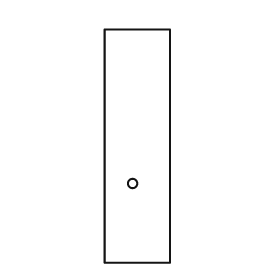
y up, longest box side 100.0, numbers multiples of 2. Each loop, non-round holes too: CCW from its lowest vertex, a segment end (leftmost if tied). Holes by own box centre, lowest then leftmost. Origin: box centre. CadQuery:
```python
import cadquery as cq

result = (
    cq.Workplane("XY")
    .moveTo(-14.0, -50.0)
    .lineTo(14.0, -50.0)
    .lineTo(14.0, 50.0)
    .lineTo(-14.0, 50.0)
    .close()
    .moveTo(-2.0, -16.0)
    .circle(2.0)
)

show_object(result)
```